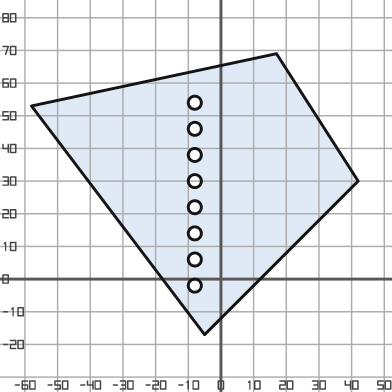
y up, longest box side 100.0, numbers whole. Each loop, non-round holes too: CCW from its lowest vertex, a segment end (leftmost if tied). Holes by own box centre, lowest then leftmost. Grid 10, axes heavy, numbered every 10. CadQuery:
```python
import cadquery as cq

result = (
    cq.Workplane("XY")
    .moveTo(-5.0, -17.0)
    .lineTo(42.0, 30.0)
    .lineTo(17.0, 69.0)
    .lineTo(-58.0, 53.0)
    .close()
    .moveTo(-8.0, -2.0)
    .circle(2.0)
    .moveTo(-8.0, 6.0)
    .circle(2.0)
    .moveTo(-8.0, 14.0)
    .circle(2.0)
    .moveTo(-8.0, 22.0)
    .circle(2.0)
    .moveTo(-8.0, 30.0)
    .circle(2.0)
    .moveTo(-8.0, 38.0)
    .circle(2.0)
    .moveTo(-8.0, 46.0)
    .circle(2.0)
    .moveTo(-8.0, 54.0)
    .circle(2.0)
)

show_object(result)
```